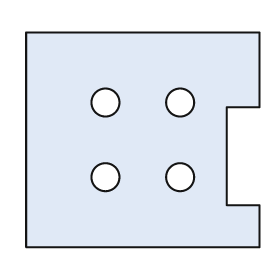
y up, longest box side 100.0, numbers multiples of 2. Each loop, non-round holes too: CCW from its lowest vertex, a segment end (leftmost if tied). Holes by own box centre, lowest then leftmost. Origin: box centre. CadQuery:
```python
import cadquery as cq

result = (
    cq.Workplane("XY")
    .moveTo(-50.0, -46.0)
    .lineTo(50.0, -46.0)
    .lineTo(50.0, -28.0)
    .lineTo(36.0, -28.0)
    .lineTo(36.0, 14.0)
    .lineTo(50.0, 14.0)
    .lineTo(50.0, 46.0)
    .lineTo(-50.0, 46.0)
    .close()
    .moveTo(-16.0, -16.0)
    .circle(6.0)
    .moveTo(16.0, -16.0)
    .circle(6.0)
    .moveTo(-16.0, 16.0)
    .circle(6.0)
    .moveTo(16.0, 16.0)
    .circle(6.0)
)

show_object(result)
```